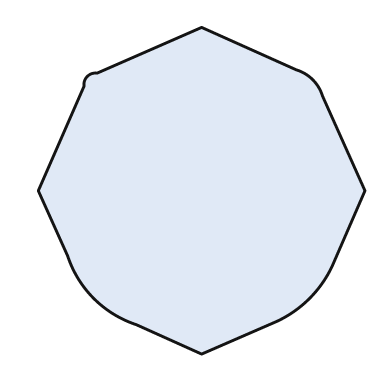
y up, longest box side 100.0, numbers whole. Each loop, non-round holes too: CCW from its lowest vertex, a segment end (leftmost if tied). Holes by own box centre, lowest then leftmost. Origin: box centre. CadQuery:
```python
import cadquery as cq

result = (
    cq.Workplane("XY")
    .moveTo(0.0, -50.0)
    .lineTo(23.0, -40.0)
    .threePointArc((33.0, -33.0), (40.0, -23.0))
    .lineTo(50.0, 0.0)
    .lineTo(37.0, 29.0)
    .threePointArc((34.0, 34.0), (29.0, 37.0))
    .lineTo(0.0, 50.0)
    .lineTo(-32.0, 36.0)
    .threePointArc((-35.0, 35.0), (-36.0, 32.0))
    .lineTo(-50.0, 0.0)
    .lineTo(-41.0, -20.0)
    .threePointArc((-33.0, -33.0), (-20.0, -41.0))
    .close()
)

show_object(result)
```